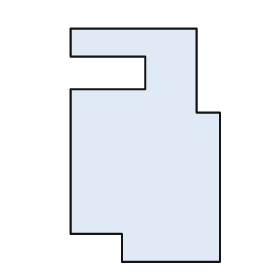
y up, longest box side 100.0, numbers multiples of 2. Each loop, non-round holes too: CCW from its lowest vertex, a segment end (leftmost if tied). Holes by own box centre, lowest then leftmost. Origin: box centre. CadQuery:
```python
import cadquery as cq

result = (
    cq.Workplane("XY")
    .moveTo(-10.0, -50.0)
    .lineTo(32.0, -50.0)
    .lineTo(32.0, 14.0)
    .lineTo(22.0, 14.0)
    .lineTo(22.0, 50.0)
    .lineTo(-32.0, 50.0)
    .lineTo(-32.0, 38.0)
    .lineTo(0.0, 38.0)
    .lineTo(0.0, 24.0)
    .lineTo(-32.0, 24.0)
    .lineTo(-32.0, -38.0)
    .lineTo(-10.0, -38.0)
    .close()
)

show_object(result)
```